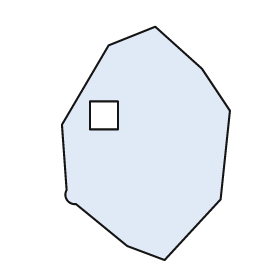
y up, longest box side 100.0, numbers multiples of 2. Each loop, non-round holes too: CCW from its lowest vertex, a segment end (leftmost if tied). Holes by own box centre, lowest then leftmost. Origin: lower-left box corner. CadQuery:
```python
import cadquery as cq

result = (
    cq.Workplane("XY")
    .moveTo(44.0, 0.0)
    .lineTo(68.0, 26.0)
    .lineTo(72.0, 64.0)
    .lineTo(60.0, 82.0)
    .lineTo(40.0, 100.0)
    .lineTo(20.0, 92.0)
    .lineTo(0.0, 58.0)
    .lineTo(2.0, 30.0)
    .threePointArc((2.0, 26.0), (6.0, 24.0))
    .lineTo(28.0, 6.0)
    .close()
    .moveTo(12.0, 56.0)
    .lineTo(24.0, 56.0)
    .lineTo(24.0, 68.0)
    .lineTo(12.0, 68.0)
    .close()
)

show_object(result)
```